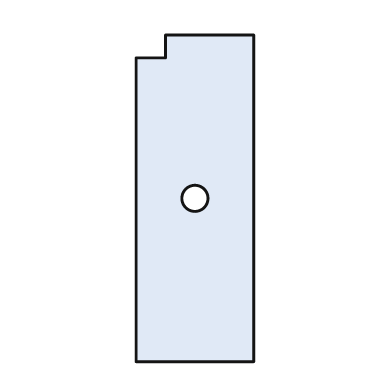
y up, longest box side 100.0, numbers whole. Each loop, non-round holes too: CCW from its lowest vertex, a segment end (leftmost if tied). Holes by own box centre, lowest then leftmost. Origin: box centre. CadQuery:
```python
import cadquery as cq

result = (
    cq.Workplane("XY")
    .moveTo(-18.0, -50.0)
    .lineTo(18.0, -50.0)
    .lineTo(18.0, 50.0)
    .lineTo(-9.0, 50.0)
    .lineTo(-9.0, 43.0)
    .lineTo(-18.0, 43.0)
    .close()
    .moveTo(0.0, 0.0)
    .circle(4.0)
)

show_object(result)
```